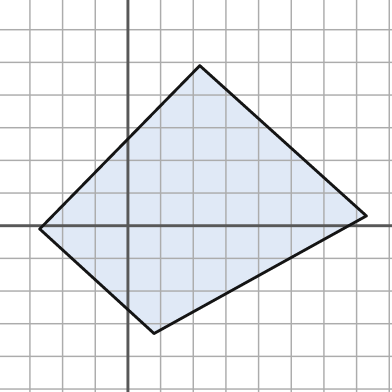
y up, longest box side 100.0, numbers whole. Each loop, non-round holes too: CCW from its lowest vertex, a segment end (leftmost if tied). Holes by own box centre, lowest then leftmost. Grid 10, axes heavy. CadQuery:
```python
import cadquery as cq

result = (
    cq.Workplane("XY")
    .moveTo(8.0, -33.0)
    .lineTo(73.0, 3.0)
    .lineTo(22.0, 49.0)
    .lineTo(-27.0, -1.0)
    .close()
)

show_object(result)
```